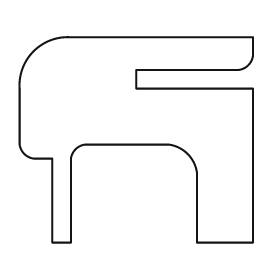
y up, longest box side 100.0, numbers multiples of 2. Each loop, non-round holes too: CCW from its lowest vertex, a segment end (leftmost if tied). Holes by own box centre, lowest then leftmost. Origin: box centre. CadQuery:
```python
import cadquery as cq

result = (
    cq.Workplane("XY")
    .moveTo(-36.0, -44.0)
    .lineTo(-28.0, -44.0)
    .lineTo(-28.0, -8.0)
    .threePointArc((-26.0, -4.0), (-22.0, -2.0))
    .lineTo(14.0, -2.0)
    .threePointArc((22.0, -6.0), (26.0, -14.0))
    .lineTo(26.0, -44.0)
    .lineTo(50.0, -44.0)
    .lineTo(50.0, 22.0)
    .lineTo(0.0, 22.0)
    .lineTo(0.0, 30.0)
    .lineTo(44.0, 30.0)
    .threePointArc((48.0, 32.0), (50.0, 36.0))
    .lineTo(50.0, 44.0)
    .lineTo(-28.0, 44.0)
    .threePointArc((-44.0, 38.0), (-50.0, 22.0))
    .lineTo(-50.0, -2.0)
    .threePointArc((-48.0, -6.0), (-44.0, -8.0))
    .lineTo(-36.0, -8.0)
    .close()
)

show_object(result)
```